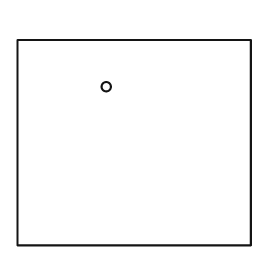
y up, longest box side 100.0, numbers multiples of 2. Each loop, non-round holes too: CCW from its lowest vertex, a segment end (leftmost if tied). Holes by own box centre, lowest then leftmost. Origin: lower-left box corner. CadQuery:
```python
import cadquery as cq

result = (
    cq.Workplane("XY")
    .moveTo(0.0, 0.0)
    .lineTo(100.0, 0.0)
    .lineTo(100.0, 88.0)
    .lineTo(0.0, 88.0)
    .close()
    .moveTo(38.0, 68.0)
    .circle(2.0)
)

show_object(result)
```